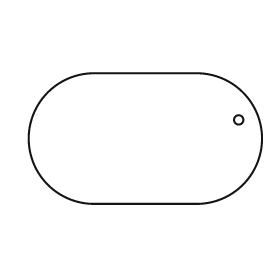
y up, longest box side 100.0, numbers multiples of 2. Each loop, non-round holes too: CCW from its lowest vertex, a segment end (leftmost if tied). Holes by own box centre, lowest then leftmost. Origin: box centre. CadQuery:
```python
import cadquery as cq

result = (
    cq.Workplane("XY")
    .moveTo(-22.0, -28.0)
    .lineTo(22.0, -28.0)
    .threePointArc((50.0, 0.0), (22.0, 28.0))
    .lineTo(-22.0, 28.0)
    .threePointArc((-50.0, 0.0), (-22.0, -28.0))
    .close()
    .moveTo(40.0, 8.0)
    .circle(2.0)
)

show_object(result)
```